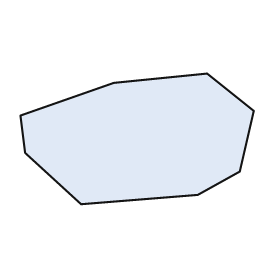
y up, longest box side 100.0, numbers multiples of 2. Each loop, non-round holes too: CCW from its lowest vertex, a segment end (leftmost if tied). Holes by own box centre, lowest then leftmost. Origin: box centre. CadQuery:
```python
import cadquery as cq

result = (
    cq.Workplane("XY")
    .moveTo(-24.0, -28.0)
    .lineTo(26.0, -24.0)
    .lineTo(44.0, -14.0)
    .lineTo(50.0, 12.0)
    .lineTo(30.0, 28.0)
    .lineTo(-10.0, 24.0)
    .lineTo(-50.0, 10.0)
    .lineTo(-48.0, -6.0)
    .close()
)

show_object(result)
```